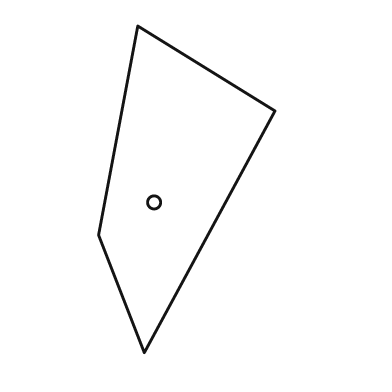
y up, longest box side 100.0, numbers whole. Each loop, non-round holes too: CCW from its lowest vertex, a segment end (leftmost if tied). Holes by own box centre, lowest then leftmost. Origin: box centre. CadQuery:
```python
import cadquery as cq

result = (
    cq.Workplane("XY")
    .moveTo(-13.0, -50.0)
    .lineTo(27.0, 24.0)
    .lineTo(-15.0, 50.0)
    .lineTo(-27.0, -14.0)
    .close()
    .moveTo(-10.0, -4.0)
    .circle(2.0)
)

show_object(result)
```